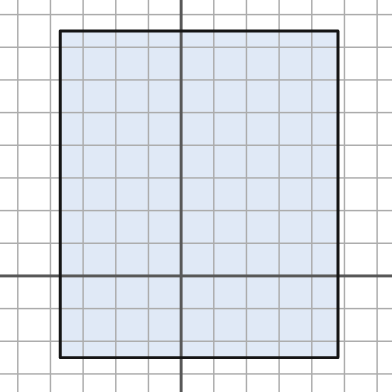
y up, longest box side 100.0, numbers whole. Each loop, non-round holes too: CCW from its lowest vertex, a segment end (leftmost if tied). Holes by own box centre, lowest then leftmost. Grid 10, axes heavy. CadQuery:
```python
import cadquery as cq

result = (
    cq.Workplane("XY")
    .moveTo(-37.0, -25.0)
    .lineTo(48.0, -25.0)
    .lineTo(48.0, 75.0)
    .lineTo(-37.0, 75.0)
    .close()
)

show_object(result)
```